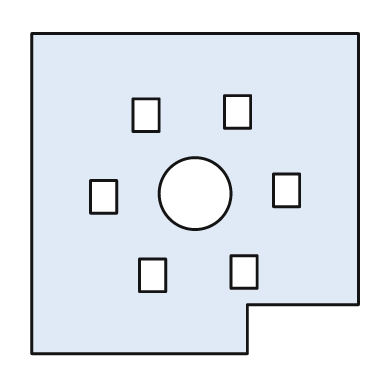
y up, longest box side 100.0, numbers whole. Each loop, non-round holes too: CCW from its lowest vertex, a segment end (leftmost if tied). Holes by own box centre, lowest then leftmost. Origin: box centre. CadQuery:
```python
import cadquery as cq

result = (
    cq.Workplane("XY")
    .moveTo(-50.0, -49.0)
    .lineTo(16.0, -49.0)
    .lineTo(16.0, -34.0)
    .lineTo(50.0, -34.0)
    .lineTo(50.0, 49.0)
    .lineTo(-50.0, 49.0)
    .close()
    .moveTo(-17.0, -30.0)
    .lineTo(-9.0, -30.0)
    .lineTo(-9.0, -20.0)
    .lineTo(-17.0, -20.0)
    .close()
    .moveTo(11.0, -29.0)
    .lineTo(19.0, -29.0)
    .lineTo(19.0, -19.0)
    .lineTo(11.0, -19.0)
    .close()
    .moveTo(-32.0, -6.0)
    .lineTo(-24.0, -6.0)
    .lineTo(-24.0, 4.0)
    .lineTo(-32.0, 4.0)
    .close()
    .moveTo(0.0, 0.0)
    .circle(11.0)
    .moveTo(24.0, -4.0)
    .lineTo(32.0, -4.0)
    .lineTo(32.0, 6.0)
    .lineTo(24.0, 6.0)
    .close()
    .moveTo(-19.0, 19.0)
    .lineTo(-11.0, 19.0)
    .lineTo(-11.0, 29.0)
    .lineTo(-19.0, 29.0)
    .close()
    .moveTo(9.0, 20.0)
    .lineTo(17.0, 20.0)
    .lineTo(17.0, 30.0)
    .lineTo(9.0, 30.0)
    .close()
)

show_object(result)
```